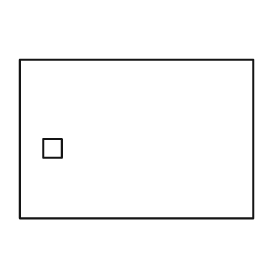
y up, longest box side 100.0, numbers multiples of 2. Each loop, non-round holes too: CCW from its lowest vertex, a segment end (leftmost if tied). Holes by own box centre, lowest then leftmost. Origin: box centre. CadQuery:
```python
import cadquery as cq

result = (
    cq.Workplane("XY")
    .moveTo(-50.0, -34.0)
    .lineTo(50.0, -34.0)
    .lineTo(50.0, 34.0)
    .lineTo(-50.0, 34.0)
    .close()
    .moveTo(-40.0, -8.0)
    .lineTo(-32.0, -8.0)
    .lineTo(-32.0, 0.0)
    .lineTo(-40.0, 0.0)
    .close()
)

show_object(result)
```